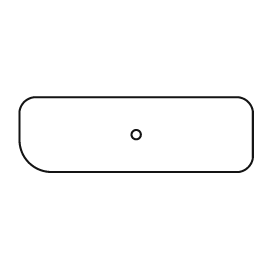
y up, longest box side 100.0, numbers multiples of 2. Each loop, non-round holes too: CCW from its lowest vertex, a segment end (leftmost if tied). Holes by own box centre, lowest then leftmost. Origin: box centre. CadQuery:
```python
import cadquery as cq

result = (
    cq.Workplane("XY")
    .moveTo(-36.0, -16.0)
    .lineTo(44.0, -16.0)
    .threePointArc((48.0, -14.0), (50.0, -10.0))
    .lineTo(50.0, 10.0)
    .threePointArc((48.0, 14.0), (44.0, 16.0))
    .lineTo(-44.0, 16.0)
    .threePointArc((-48.0, 14.0), (-50.0, 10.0))
    .lineTo(-50.0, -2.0)
    .threePointArc((-46.0, -12.0), (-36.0, -16.0))
    .close()
    .moveTo(0.0, 0.0)
    .circle(2.0)
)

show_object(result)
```